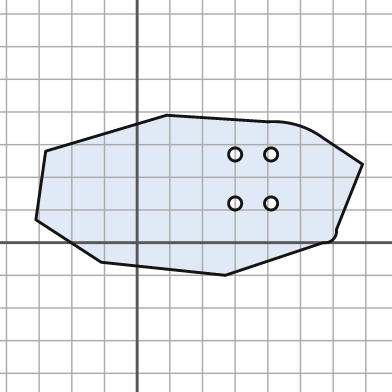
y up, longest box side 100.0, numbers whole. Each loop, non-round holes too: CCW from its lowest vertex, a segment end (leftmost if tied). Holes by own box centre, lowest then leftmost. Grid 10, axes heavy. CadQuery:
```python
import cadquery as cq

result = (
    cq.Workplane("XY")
    .moveTo(27.0, -10.0)
    .lineTo(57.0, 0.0)
    .threePointArc((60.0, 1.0), (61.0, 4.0))
    .lineTo(69.0, 24.0)
    .lineTo(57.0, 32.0)
    .threePointArc((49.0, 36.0), (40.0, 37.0))
    .lineTo(9.0, 39.0)
    .lineTo(-28.0, 28.0)
    .lineTo(-31.0, 7.0)
    .lineTo(-11.0, -6.0)
    .close()
    .moveTo(30.0, 12.0)
    .circle(2.0)
    .moveTo(41.0, 12.0)
    .circle(2.0)
    .moveTo(30.0, 27.0)
    .circle(2.0)
    .moveTo(41.0, 27.0)
    .circle(2.0)
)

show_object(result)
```